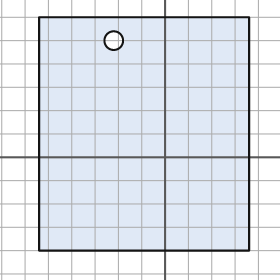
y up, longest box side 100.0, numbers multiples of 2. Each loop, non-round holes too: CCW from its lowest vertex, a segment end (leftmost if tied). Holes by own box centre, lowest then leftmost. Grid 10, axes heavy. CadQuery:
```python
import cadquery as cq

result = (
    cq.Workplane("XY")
    .moveTo(-54.0, -40.0)
    .lineTo(36.0, -40.0)
    .lineTo(36.0, 60.0)
    .lineTo(-54.0, 60.0)
    .close()
    .moveTo(-22.0, 50.0)
    .circle(4.0)
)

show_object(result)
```